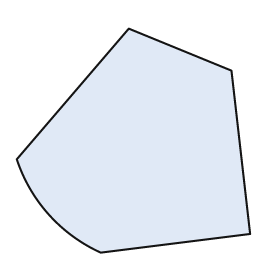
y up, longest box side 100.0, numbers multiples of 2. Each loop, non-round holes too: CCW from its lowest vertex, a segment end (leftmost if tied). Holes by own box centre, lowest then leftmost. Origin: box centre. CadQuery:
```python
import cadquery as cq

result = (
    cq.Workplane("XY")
    .moveTo(-14.0, -48.0)
    .lineTo(50.0, -40.0)
    .lineTo(42.0, 30.0)
    .lineTo(-2.0, 48.0)
    .lineTo(-50.0, -8.0)
    .threePointArc((-36.0, -32.0), (-14.0, -48.0))
    .close()
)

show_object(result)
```